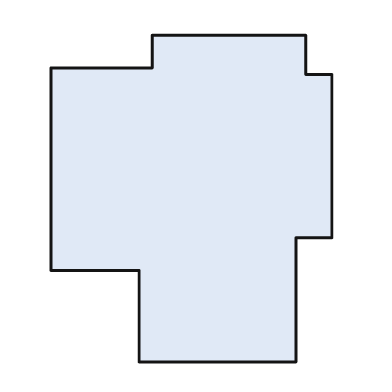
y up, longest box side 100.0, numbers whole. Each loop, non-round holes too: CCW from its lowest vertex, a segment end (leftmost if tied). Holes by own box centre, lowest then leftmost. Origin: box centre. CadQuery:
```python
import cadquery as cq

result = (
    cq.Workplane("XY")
    .moveTo(-16.0, -50.0)
    .lineTo(32.0, -50.0)
    .lineTo(32.0, -12.0)
    .lineTo(43.0, -12.0)
    .lineTo(43.0, 38.0)
    .lineTo(35.0, 38.0)
    .lineTo(35.0, 50.0)
    .lineTo(-12.0, 50.0)
    .lineTo(-12.0, 40.0)
    .lineTo(-43.0, 40.0)
    .lineTo(-43.0, -22.0)
    .lineTo(-16.0, -22.0)
    .close()
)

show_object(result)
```